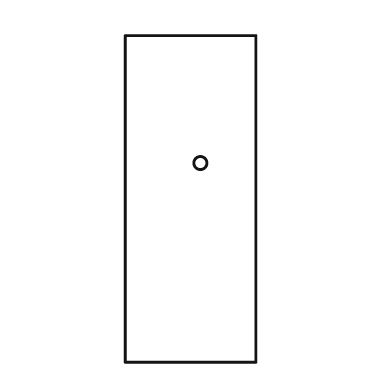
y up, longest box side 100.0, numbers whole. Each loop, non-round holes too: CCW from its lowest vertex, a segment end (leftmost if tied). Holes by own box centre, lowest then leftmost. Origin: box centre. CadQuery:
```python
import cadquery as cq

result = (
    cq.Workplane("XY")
    .moveTo(-20.0, -50.0)
    .lineTo(20.0, -50.0)
    .lineTo(20.0, 50.0)
    .lineTo(-20.0, 50.0)
    .close()
    .moveTo(3.0, 11.0)
    .circle(2.0)
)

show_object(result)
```